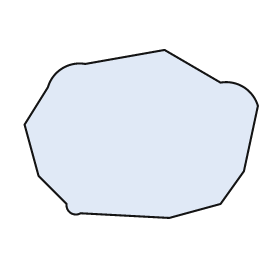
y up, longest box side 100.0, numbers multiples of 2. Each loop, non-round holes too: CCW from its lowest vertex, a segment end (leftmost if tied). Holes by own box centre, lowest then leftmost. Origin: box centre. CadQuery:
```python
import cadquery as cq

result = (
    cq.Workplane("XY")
    .moveTo(12.0, -36.0)
    .lineTo(34.0, -30.0)
    .lineTo(44.0, -16.0)
    .lineTo(50.0, 12.0)
    .threePointArc((44.0, 20.0), (34.0, 22.0))
    .lineTo(10.0, 36.0)
    .lineTo(-24.0, 30.0)
    .threePointArc((-34.0, 28.0), (-40.0, 20.0))
    .lineTo(-50.0, 4.0)
    .lineTo(-44.0, -18.0)
    .lineTo(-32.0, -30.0)
    .threePointArc((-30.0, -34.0), (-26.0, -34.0))
    .close()
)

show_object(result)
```